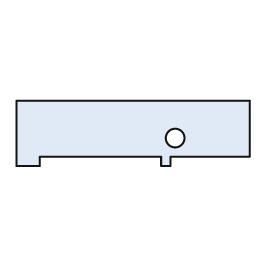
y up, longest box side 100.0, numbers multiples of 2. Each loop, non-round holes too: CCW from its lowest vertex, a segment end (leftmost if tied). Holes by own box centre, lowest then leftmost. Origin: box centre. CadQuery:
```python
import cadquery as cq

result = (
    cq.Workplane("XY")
    .moveTo(-50.0, -14.0)
    .lineTo(-40.0, -14.0)
    .lineTo(-40.0, -10.0)
    .lineTo(12.0, -10.0)
    .lineTo(12.0, -14.0)
    .lineTo(16.0, -14.0)
    .lineTo(16.0, -10.0)
    .lineTo(50.0, -10.0)
    .lineTo(50.0, 14.0)
    .lineTo(-50.0, 14.0)
    .close()
    .moveTo(18.0, -2.0)
    .circle(4.0)
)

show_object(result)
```